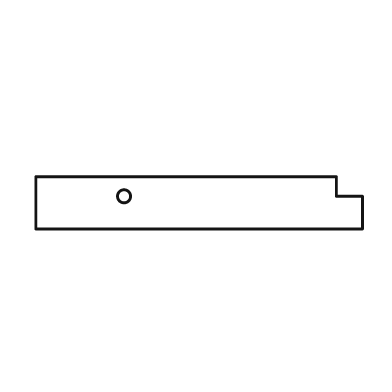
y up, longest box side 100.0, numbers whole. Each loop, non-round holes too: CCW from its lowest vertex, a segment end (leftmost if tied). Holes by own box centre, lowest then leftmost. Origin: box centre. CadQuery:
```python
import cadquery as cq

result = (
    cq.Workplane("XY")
    .moveTo(-50.0, -8.0)
    .lineTo(50.0, -8.0)
    .lineTo(50.0, 2.0)
    .lineTo(42.0, 2.0)
    .lineTo(42.0, 8.0)
    .lineTo(-50.0, 8.0)
    .close()
    .moveTo(-23.0, 2.0)
    .circle(2.0)
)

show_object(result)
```